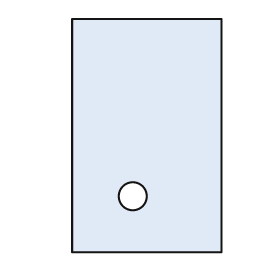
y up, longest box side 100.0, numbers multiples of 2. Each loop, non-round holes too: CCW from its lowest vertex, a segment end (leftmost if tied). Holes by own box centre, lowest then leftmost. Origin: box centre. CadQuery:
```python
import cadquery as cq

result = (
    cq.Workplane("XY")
    .moveTo(-32.0, -50.0)
    .lineTo(32.0, -50.0)
    .lineTo(32.0, 50.0)
    .lineTo(-32.0, 50.0)
    .close()
    .moveTo(-6.0, -26.0)
    .circle(6.0)
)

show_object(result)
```